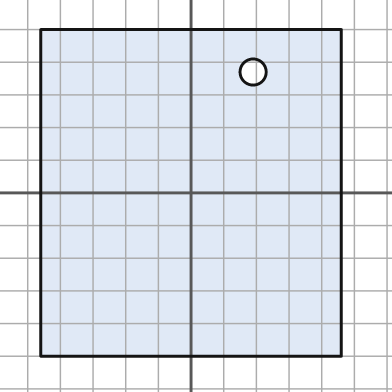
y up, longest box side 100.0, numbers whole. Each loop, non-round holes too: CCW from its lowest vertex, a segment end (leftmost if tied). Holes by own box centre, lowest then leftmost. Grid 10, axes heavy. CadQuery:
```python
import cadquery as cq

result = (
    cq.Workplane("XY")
    .moveTo(-46.0, -50.0)
    .lineTo(46.0, -50.0)
    .lineTo(46.0, 50.0)
    .lineTo(-46.0, 50.0)
    .close()
    .moveTo(19.0, 37.0)
    .circle(4.0)
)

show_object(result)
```